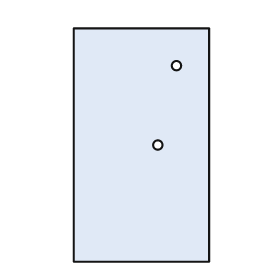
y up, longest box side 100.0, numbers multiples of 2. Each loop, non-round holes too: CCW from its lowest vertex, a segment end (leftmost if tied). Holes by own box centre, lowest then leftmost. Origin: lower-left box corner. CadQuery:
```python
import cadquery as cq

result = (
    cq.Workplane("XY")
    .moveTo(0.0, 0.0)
    .lineTo(58.0, 0.0)
    .lineTo(58.0, 100.0)
    .lineTo(0.0, 100.0)
    .close()
    .moveTo(36.0, 50.0)
    .circle(2.0)
    .moveTo(44.0, 84.0)
    .circle(2.0)
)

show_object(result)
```